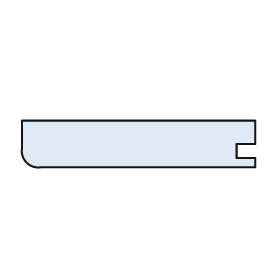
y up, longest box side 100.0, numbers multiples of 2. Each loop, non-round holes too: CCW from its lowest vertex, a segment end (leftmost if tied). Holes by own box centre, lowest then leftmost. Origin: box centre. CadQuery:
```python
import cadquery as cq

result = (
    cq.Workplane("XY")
    .moveTo(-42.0, -10.0)
    .lineTo(50.0, -10.0)
    .lineTo(50.0, -6.0)
    .lineTo(42.0, -6.0)
    .lineTo(42.0, 0.0)
    .lineTo(50.0, 0.0)
    .lineTo(50.0, 10.0)
    .lineTo(-50.0, 10.0)
    .lineTo(-50.0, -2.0)
    .threePointArc((-48.0, -8.0), (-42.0, -10.0))
    .close()
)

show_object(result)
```